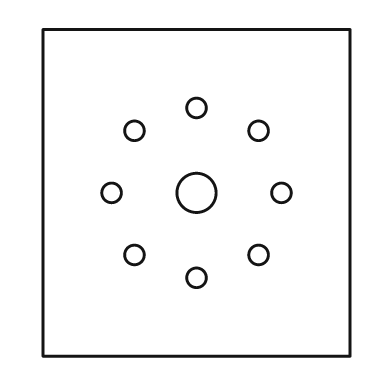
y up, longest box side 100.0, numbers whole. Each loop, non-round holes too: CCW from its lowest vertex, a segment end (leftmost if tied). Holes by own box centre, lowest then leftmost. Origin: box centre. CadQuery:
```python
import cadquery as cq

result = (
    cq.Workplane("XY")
    .moveTo(-47.0, -50.0)
    .lineTo(47.0, -50.0)
    .lineTo(47.0, 50.0)
    .lineTo(-47.0, 50.0)
    .close()
    .moveTo(0.0, -26.0)
    .circle(3.0)
    .moveTo(-19.0, -19.0)
    .circle(3.0)
    .moveTo(19.0, -19.0)
    .circle(3.0)
    .moveTo(-26.0, 0.0)
    .circle(3.0)
    .moveTo(0.0, 0.0)
    .circle(6.0)
    .moveTo(26.0, 0.0)
    .circle(3.0)
    .moveTo(-19.0, 19.0)
    .circle(3.0)
    .moveTo(19.0, 19.0)
    .circle(3.0)
    .moveTo(0.0, 26.0)
    .circle(3.0)
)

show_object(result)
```